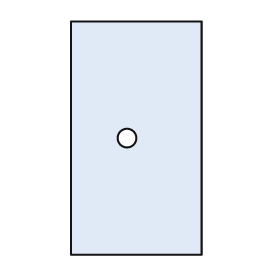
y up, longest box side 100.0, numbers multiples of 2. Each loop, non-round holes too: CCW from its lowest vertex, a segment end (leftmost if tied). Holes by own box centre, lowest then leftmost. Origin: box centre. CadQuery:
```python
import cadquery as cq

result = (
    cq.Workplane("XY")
    .moveTo(-28.0, -50.0)
    .lineTo(28.0, -50.0)
    .lineTo(28.0, 50.0)
    .lineTo(-28.0, 50.0)
    .close()
    .moveTo(-4.0, 0.0)
    .circle(4.0)
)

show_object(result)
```